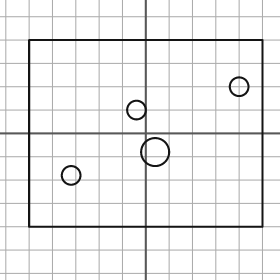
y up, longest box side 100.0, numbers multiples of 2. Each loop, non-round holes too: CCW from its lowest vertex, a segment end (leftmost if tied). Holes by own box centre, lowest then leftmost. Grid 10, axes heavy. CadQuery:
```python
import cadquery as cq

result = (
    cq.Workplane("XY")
    .moveTo(-50.0, -40.0)
    .lineTo(50.0, -40.0)
    .lineTo(50.0, 40.0)
    .lineTo(-50.0, 40.0)
    .close()
    .moveTo(-32.0, -18.0)
    .circle(4.0)
    .moveTo(4.0, -8.0)
    .circle(6.0)
    .moveTo(-4.0, 10.0)
    .circle(4.0)
    .moveTo(40.0, 20.0)
    .circle(4.0)
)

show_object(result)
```